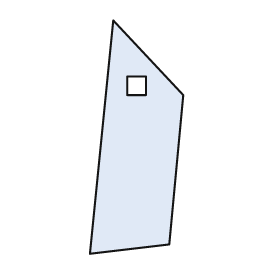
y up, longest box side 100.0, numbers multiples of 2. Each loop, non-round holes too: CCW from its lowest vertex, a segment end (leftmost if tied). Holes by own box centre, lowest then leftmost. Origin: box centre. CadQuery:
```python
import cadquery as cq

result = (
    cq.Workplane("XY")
    .moveTo(-20.0, -50.0)
    .lineTo(14.0, -46.0)
    .lineTo(20.0, 18.0)
    .lineTo(-10.0, 50.0)
    .close()
    .moveTo(-4.0, 18.0)
    .lineTo(4.0, 18.0)
    .lineTo(4.0, 26.0)
    .lineTo(-4.0, 26.0)
    .close()
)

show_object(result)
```